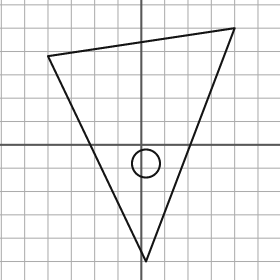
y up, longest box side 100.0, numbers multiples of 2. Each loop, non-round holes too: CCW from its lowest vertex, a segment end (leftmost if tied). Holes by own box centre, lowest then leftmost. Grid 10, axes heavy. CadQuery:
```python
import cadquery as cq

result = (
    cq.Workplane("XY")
    .moveTo(2.0, -50.0)
    .lineTo(40.0, 50.0)
    .lineTo(-40.0, 38.0)
    .close()
    .moveTo(2.0, -8.0)
    .circle(6.0)
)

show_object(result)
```